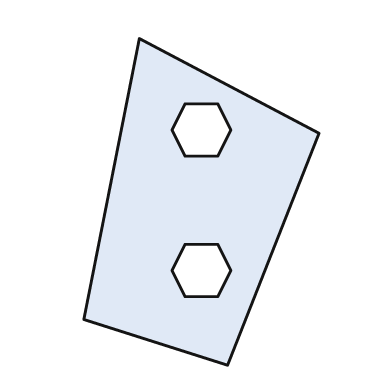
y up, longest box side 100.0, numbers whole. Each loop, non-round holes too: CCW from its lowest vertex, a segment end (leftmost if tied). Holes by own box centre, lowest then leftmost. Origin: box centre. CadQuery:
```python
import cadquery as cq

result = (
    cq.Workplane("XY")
    .moveTo(8.0, -50.0)
    .lineTo(36.0, 21.0)
    .lineTo(-19.0, 50.0)
    .lineTo(-36.0, -36.0)
    .close()
    .moveTo(-5.0, -29.0)
    .lineTo(5.0, -29.0)
    .lineTo(9.0, -21.0)
    .lineTo(5.0, -13.0)
    .lineTo(-5.0, -13.0)
    .lineTo(-9.0, -21.0)
    .close()
    .moveTo(-5.0, 14.0)
    .lineTo(5.0, 14.0)
    .lineTo(9.0, 22.0)
    .lineTo(5.0, 30.0)
    .lineTo(-5.0, 30.0)
    .lineTo(-9.0, 22.0)
    .close()
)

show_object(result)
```